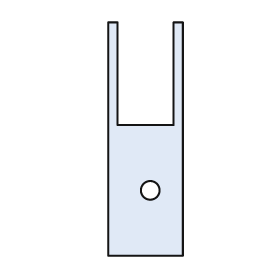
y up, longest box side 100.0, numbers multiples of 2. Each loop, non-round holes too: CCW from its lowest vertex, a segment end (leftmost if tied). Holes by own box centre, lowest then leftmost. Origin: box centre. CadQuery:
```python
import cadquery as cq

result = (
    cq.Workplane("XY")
    .moveTo(-16.0, -50.0)
    .lineTo(16.0, -50.0)
    .lineTo(16.0, 50.0)
    .lineTo(12.0, 50.0)
    .lineTo(12.0, 6.0)
    .lineTo(-12.0, 6.0)
    .lineTo(-12.0, 50.0)
    .lineTo(-16.0, 50.0)
    .close()
    .moveTo(2.0, -22.0)
    .circle(4.0)
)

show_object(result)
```